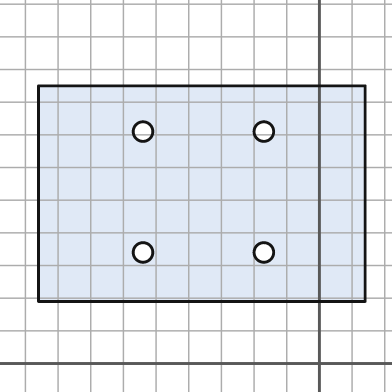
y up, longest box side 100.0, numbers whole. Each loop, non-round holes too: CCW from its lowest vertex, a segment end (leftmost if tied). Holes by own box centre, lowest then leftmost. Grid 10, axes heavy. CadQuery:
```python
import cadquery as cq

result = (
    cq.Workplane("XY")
    .moveTo(-86.0, 19.0)
    .lineTo(14.0, 19.0)
    .lineTo(14.0, 85.0)
    .lineTo(-86.0, 85.0)
    .close()
    .moveTo(-54.0, 34.0)
    .circle(3.0)
    .moveTo(-17.0, 34.0)
    .circle(3.0)
    .moveTo(-54.0, 71.0)
    .circle(3.0)
    .moveTo(-17.0, 71.0)
    .circle(3.0)
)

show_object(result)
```